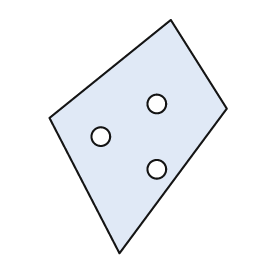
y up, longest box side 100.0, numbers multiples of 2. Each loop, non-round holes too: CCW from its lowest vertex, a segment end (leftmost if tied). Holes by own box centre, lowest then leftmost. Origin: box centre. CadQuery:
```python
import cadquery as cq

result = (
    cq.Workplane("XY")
    .moveTo(-8.0, -50.0)
    .lineTo(38.0, 12.0)
    .lineTo(14.0, 50.0)
    .lineTo(-38.0, 8.0)
    .close()
    .moveTo(8.0, -14.0)
    .circle(4.0)
    .moveTo(-16.0, 0.0)
    .circle(4.0)
    .moveTo(8.0, 14.0)
    .circle(4.0)
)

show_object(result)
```